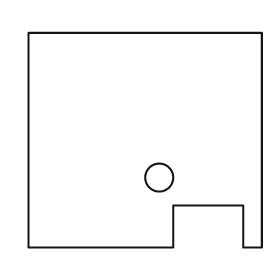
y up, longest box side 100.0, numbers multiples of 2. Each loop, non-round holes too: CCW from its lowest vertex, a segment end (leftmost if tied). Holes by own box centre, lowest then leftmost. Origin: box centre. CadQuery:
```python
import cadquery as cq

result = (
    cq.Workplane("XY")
    .moveTo(-50.0, -46.0)
    .lineTo(12.0, -46.0)
    .lineTo(12.0, -28.0)
    .lineTo(42.0, -28.0)
    .lineTo(42.0, -46.0)
    .lineTo(50.0, -46.0)
    .lineTo(50.0, 46.0)
    .lineTo(-50.0, 46.0)
    .close()
    .moveTo(6.0, -16.0)
    .circle(6.0)
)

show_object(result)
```